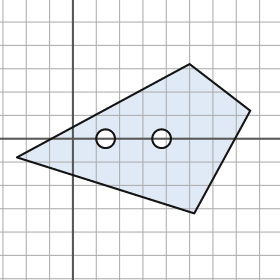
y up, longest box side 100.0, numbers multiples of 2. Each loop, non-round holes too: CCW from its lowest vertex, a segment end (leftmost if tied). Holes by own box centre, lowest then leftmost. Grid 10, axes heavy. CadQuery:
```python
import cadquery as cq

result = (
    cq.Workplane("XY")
    .moveTo(52.0, -32.0)
    .lineTo(76.0, 12.0)
    .lineTo(50.0, 32.0)
    .lineTo(-24.0, -8.0)
    .close()
    .moveTo(14.0, 0.0)
    .circle(4.0)
    .moveTo(38.0, 0.0)
    .circle(4.0)
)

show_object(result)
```